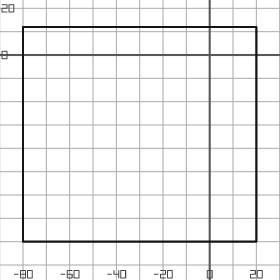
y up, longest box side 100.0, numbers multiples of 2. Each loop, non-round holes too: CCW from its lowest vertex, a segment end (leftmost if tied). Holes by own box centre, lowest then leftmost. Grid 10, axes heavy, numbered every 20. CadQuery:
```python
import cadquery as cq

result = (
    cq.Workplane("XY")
    .moveTo(-80.0, -80.0)
    .lineTo(20.0, -80.0)
    .lineTo(20.0, 12.0)
    .lineTo(-80.0, 12.0)
    .close()
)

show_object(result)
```